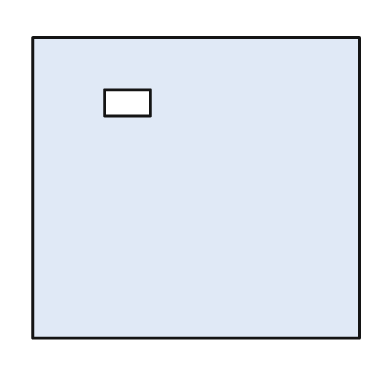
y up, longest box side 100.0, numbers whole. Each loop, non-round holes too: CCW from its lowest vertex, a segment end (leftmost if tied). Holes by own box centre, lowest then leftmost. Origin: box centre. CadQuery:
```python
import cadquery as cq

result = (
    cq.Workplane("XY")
    .moveTo(-50.0, -46.0)
    .lineTo(50.0, -46.0)
    .lineTo(50.0, 46.0)
    .lineTo(-50.0, 46.0)
    .close()
    .moveTo(-28.0, 22.0)
    .lineTo(-14.0, 22.0)
    .lineTo(-14.0, 30.0)
    .lineTo(-28.0, 30.0)
    .close()
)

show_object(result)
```